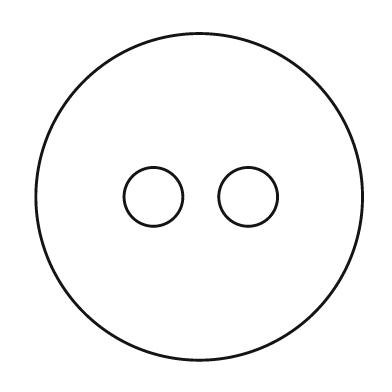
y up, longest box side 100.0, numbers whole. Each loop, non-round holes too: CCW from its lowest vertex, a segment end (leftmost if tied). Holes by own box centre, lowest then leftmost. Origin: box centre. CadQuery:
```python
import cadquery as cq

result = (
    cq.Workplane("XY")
    .moveTo(0.0, 0.0)
    .circle(50.0)
    .moveTo(-14.0, 0.0)
    .circle(9.0)
    .moveTo(15.0, 0.0)
    .circle(9.0)
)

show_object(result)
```